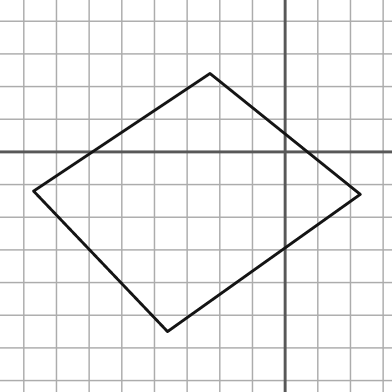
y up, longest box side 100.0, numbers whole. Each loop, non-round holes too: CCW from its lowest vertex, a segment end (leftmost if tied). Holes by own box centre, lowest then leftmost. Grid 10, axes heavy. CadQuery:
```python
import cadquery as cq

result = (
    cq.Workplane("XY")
    .moveTo(-36.0, -55.0)
    .lineTo(23.0, -13.0)
    .lineTo(-23.0, 24.0)
    .lineTo(-77.0, -12.0)
    .close()
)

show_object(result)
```